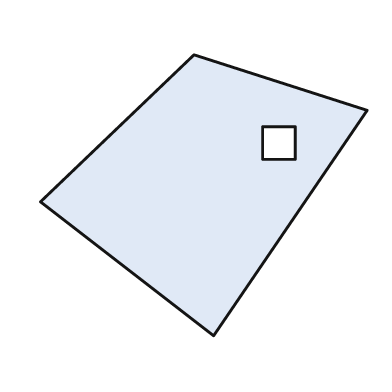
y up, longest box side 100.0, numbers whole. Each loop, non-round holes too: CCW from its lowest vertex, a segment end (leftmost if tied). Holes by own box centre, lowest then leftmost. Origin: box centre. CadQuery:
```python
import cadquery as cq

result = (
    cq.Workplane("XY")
    .moveTo(3.0, -43.0)
    .lineTo(50.0, 26.0)
    .lineTo(-3.0, 43.0)
    .lineTo(-50.0, -2.0)
    .close()
    .moveTo(18.0, 11.0)
    .lineTo(28.0, 11.0)
    .lineTo(28.0, 21.0)
    .lineTo(18.0, 21.0)
    .close()
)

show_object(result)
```